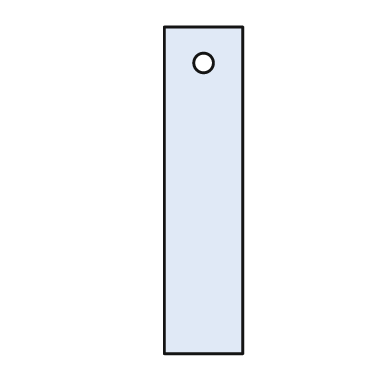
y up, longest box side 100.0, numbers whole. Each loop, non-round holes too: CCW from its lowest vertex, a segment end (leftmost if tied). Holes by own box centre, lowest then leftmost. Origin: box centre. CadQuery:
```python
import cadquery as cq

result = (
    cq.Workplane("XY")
    .moveTo(-12.0, -50.0)
    .lineTo(12.0, -50.0)
    .lineTo(12.0, 50.0)
    .lineTo(-12.0, 50.0)
    .close()
    .moveTo(0.0, 39.0)
    .circle(3.0)
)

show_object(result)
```